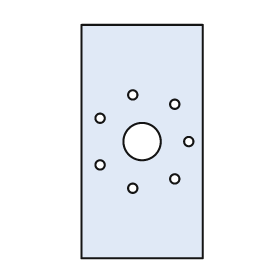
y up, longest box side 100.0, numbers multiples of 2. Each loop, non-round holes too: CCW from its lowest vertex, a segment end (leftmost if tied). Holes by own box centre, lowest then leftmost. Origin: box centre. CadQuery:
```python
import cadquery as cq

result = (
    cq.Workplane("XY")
    .moveTo(-26.0, -50.0)
    .lineTo(26.0, -50.0)
    .lineTo(26.0, 50.0)
    .lineTo(-26.0, 50.0)
    .close()
    .moveTo(-4.0, -20.0)
    .circle(2.0)
    .moveTo(14.0, -16.0)
    .circle(2.0)
    .moveTo(-18.0, -10.0)
    .circle(2.0)
    .moveTo(0.0, 0.0)
    .circle(8.0)
    .moveTo(20.0, 0.0)
    .circle(2.0)
    .moveTo(-18.0, 10.0)
    .circle(2.0)
    .moveTo(14.0, 16.0)
    .circle(2.0)
    .moveTo(-4.0, 20.0)
    .circle(2.0)
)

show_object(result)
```